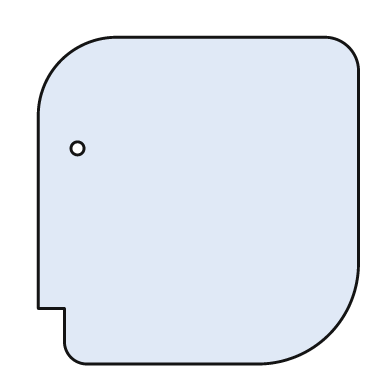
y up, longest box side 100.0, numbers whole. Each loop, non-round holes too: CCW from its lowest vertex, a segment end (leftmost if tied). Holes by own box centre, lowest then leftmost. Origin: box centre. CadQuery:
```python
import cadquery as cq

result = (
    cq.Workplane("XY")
    .moveTo(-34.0, -50.0)
    .lineTo(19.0, -50.0)
    .threePointArc((40.0, -41.0), (49.0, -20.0))
    .lineTo(49.0, 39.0)
    .threePointArc((46.0, 47.0), (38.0, 50.0))
    .lineTo(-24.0, 50.0)
    .threePointArc((-42.0, 43.0), (-49.0, 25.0))
    .lineTo(-49.0, -33.0)
    .lineTo(-41.0, -33.0)
    .lineTo(-41.0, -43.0)
    .threePointArc((-39.0, -48.0), (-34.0, -50.0))
    .close()
    .moveTo(-37.0, 16.0)
    .circle(2.0)
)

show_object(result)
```